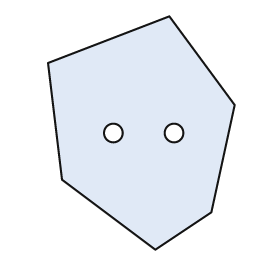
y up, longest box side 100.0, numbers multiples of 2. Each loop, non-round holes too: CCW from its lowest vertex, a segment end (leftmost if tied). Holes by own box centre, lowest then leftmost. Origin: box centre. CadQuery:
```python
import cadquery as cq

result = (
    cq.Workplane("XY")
    .moveTo(6.0, -50.0)
    .lineTo(30.0, -34.0)
    .lineTo(40.0, 12.0)
    .lineTo(12.0, 50.0)
    .lineTo(-40.0, 30.0)
    .lineTo(-34.0, -20.0)
    .close()
    .moveTo(-12.0, 0.0)
    .circle(4.0)
    .moveTo(14.0, 0.0)
    .circle(4.0)
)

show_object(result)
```